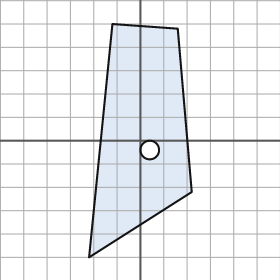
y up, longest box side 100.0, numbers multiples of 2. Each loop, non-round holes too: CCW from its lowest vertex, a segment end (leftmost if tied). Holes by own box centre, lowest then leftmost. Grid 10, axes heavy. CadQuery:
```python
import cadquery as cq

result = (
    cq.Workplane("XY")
    .moveTo(-22.0, -50.0)
    .lineTo(22.0, -22.0)
    .lineTo(16.0, 48.0)
    .lineTo(-12.0, 50.0)
    .close()
    .moveTo(4.0, -4.0)
    .circle(4.0)
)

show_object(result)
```